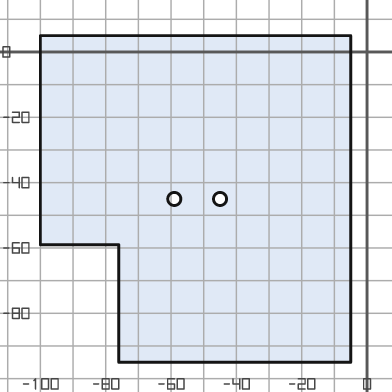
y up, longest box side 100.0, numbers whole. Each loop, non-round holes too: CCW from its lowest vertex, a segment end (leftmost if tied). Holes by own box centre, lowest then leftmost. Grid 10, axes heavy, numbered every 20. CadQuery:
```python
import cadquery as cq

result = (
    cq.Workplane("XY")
    .moveTo(-76.0, -95.0)
    .lineTo(-5.0, -95.0)
    .lineTo(-5.0, 5.0)
    .lineTo(-100.0, 5.0)
    .lineTo(-100.0, -59.0)
    .lineTo(-76.0, -59.0)
    .close()
    .moveTo(-59.0, -45.0)
    .circle(2.0)
    .moveTo(-45.0, -45.0)
    .circle(2.0)
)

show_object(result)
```